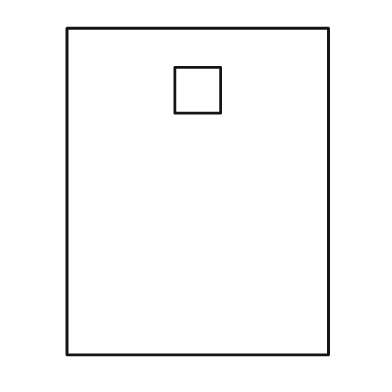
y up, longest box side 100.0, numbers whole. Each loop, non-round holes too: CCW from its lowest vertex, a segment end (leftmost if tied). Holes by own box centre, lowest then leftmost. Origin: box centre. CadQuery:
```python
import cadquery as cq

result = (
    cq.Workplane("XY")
    .moveTo(-40.0, -50.0)
    .lineTo(40.0, -50.0)
    .lineTo(40.0, 50.0)
    .lineTo(-40.0, 50.0)
    .close()
    .moveTo(-7.0, 24.0)
    .lineTo(7.0, 24.0)
    .lineTo(7.0, 38.0)
    .lineTo(-7.0, 38.0)
    .close()
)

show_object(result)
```